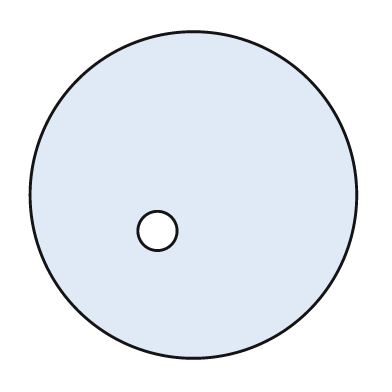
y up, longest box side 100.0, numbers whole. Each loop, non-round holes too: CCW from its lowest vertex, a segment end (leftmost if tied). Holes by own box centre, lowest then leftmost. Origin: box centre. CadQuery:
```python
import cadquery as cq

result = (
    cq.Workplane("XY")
    .moveTo(0.0, 0.0)
    .circle(50.0)
    .moveTo(-11.0, -11.0)
    .circle(6.0)
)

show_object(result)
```